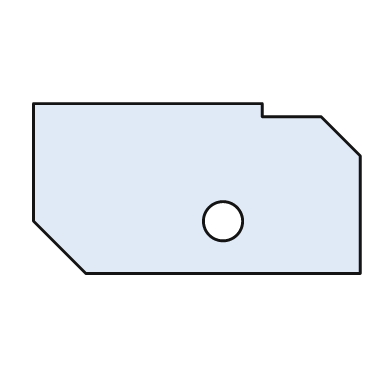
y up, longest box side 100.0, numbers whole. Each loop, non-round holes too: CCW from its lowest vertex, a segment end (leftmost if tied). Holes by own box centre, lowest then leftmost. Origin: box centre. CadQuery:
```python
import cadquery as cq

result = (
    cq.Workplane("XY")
    .moveTo(-34.0, -26.0)
    .lineTo(50.0, -26.0)
    .lineTo(50.0, 10.0)
    .lineTo(38.0, 22.0)
    .lineTo(20.0, 22.0)
    .lineTo(20.0, 26.0)
    .lineTo(-50.0, 26.0)
    .lineTo(-50.0, -10.0)
    .close()
    .moveTo(8.0, -10.0)
    .circle(6.0)
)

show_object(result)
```